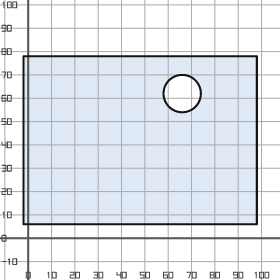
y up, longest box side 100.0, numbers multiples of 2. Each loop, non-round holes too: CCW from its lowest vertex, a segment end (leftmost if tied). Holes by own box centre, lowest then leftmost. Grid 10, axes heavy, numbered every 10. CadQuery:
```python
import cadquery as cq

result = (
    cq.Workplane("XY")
    .moveTo(-2.0, 6.0)
    .lineTo(98.0, 6.0)
    .lineTo(98.0, 78.0)
    .lineTo(-2.0, 78.0)
    .close()
    .moveTo(66.0, 62.0)
    .circle(8.0)
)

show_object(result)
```